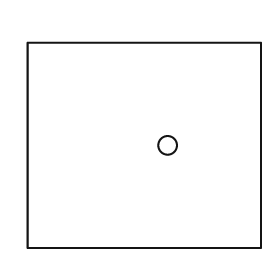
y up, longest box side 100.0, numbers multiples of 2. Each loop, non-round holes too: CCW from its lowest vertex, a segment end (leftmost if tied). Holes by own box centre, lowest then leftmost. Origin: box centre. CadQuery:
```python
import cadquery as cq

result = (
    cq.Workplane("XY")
    .moveTo(-50.0, -44.0)
    .lineTo(50.0, -44.0)
    .lineTo(50.0, 44.0)
    .lineTo(-50.0, 44.0)
    .close()
    .moveTo(10.0, 0.0)
    .circle(4.0)
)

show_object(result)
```